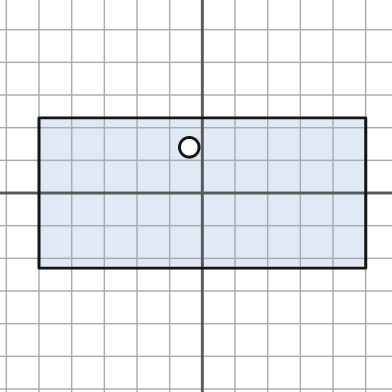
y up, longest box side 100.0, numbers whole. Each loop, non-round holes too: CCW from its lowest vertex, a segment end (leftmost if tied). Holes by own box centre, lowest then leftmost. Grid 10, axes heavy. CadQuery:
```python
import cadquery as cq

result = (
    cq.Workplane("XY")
    .moveTo(-50.0, -23.0)
    .lineTo(50.0, -23.0)
    .lineTo(50.0, 23.0)
    .lineTo(-50.0, 23.0)
    .close()
    .moveTo(-4.0, 14.0)
    .circle(3.0)
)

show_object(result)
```